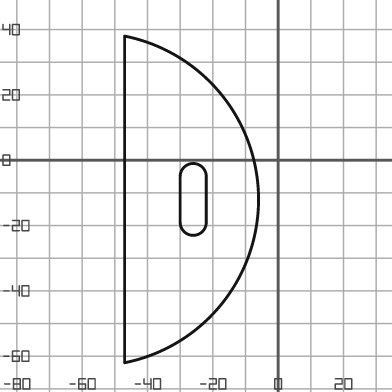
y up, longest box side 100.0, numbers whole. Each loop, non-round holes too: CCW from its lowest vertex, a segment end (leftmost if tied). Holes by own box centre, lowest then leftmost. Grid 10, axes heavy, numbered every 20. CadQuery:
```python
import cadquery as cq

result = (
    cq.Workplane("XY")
    .moveTo(-47.0, -62.0)
    .threePointArc((-6.0, -12.0), (-47.0, 38.0))
    .close()
    .moveTo(-30.0, -19.0)
    .threePointArc((-26.0, -23.0), (-22.0, -19.0))
    .lineTo(-22.0, -5.0)
    .threePointArc((-26.0, -1.0), (-30.0, -5.0))
    .close()
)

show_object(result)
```